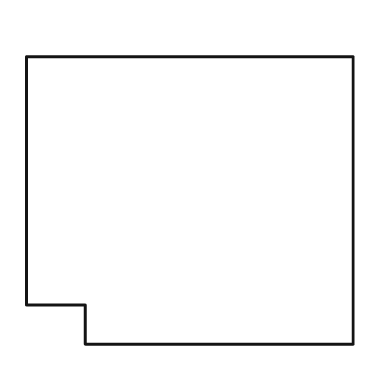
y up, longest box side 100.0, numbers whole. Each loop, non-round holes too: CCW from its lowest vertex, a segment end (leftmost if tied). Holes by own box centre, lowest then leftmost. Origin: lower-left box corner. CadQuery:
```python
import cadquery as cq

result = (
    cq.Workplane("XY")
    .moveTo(18.0, 0.0)
    .lineTo(100.0, 0.0)
    .lineTo(100.0, 88.0)
    .lineTo(0.0, 88.0)
    .lineTo(0.0, 12.0)
    .lineTo(18.0, 12.0)
    .close()
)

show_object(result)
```